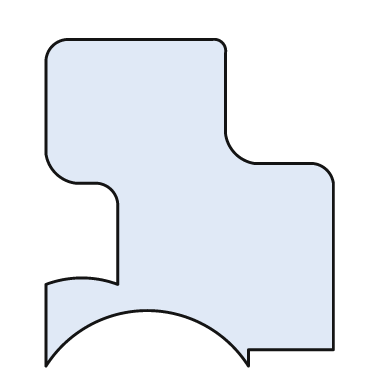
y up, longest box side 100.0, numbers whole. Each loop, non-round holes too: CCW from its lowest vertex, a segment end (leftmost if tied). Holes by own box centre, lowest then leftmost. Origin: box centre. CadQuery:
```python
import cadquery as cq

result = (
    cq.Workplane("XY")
    .moveTo(-44.0, -50.0)
    .threePointArc((-13.0, -33.0), (18.0, -50.0))
    .lineTo(18.0, -45.0)
    .lineTo(44.0, -45.0)
    .lineTo(44.0, 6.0)
    .threePointArc((42.0, 10.0), (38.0, 12.0))
    .lineTo(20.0, 12.0)
    .threePointArc((14.0, 15.0), (11.0, 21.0))
    .lineTo(11.0, 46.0)
    .threePointArc((10.0, 49.0), (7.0, 50.0))
    .lineTo(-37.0, 50.0)
    .threePointArc((-42.0, 48.0), (-44.0, 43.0))
    .lineTo(-44.0, 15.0)
    .threePointArc((-41.0, 9.0), (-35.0, 6.0))
    .lineTo(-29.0, 6.0)
    .threePointArc((-24.0, 4.0), (-22.0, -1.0))
    .lineTo(-22.0, -25.0)
    .threePointArc((-33.0, -23.0), (-44.0, -25.0))
    .close()
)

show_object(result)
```